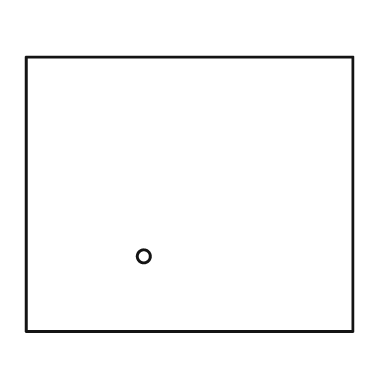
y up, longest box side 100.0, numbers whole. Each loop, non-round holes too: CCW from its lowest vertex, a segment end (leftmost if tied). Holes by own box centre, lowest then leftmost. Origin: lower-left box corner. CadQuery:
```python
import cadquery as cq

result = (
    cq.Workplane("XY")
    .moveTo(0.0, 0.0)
    .lineTo(100.0, 0.0)
    .lineTo(100.0, 84.0)
    .lineTo(0.0, 84.0)
    .close()
    .moveTo(36.0, 23.0)
    .circle(2.0)
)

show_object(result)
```